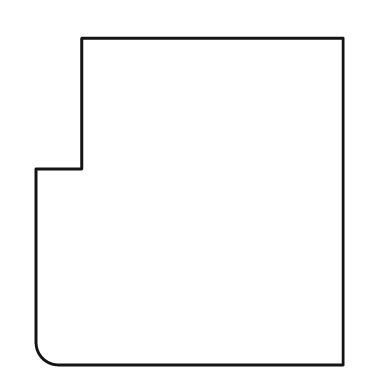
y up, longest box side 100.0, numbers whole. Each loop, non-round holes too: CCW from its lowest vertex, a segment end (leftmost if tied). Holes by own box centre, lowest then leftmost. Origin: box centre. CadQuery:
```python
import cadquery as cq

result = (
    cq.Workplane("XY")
    .moveTo(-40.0, -50.0)
    .lineTo(47.0, -50.0)
    .lineTo(47.0, 50.0)
    .lineTo(-33.0, 50.0)
    .lineTo(-33.0, 10.0)
    .lineTo(-47.0, 10.0)
    .lineTo(-47.0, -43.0)
    .threePointArc((-45.0, -48.0), (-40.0, -50.0))
    .close()
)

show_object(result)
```